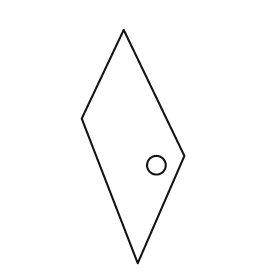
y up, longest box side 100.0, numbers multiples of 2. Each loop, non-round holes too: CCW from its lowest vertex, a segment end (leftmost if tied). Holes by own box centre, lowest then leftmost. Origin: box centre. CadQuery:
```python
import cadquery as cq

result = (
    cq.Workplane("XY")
    .moveTo(2.0, -50.0)
    .lineTo(22.0, -4.0)
    .lineTo(-4.0, 50.0)
    .lineTo(-22.0, 12.0)
    .close()
    .moveTo(10.0, -8.0)
    .circle(4.0)
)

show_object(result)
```